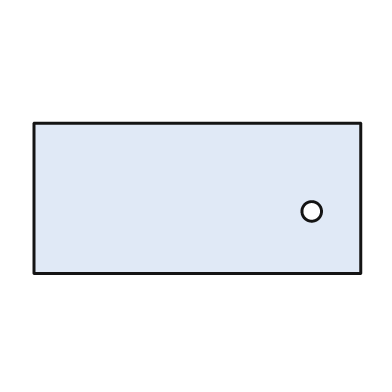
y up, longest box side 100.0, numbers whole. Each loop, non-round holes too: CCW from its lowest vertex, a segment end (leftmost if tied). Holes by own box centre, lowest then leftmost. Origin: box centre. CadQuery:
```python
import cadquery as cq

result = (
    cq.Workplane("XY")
    .moveTo(-50.0, -23.0)
    .lineTo(50.0, -23.0)
    .lineTo(50.0, 23.0)
    .lineTo(-50.0, 23.0)
    .close()
    .moveTo(35.0, -4.0)
    .circle(3.0)
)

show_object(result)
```